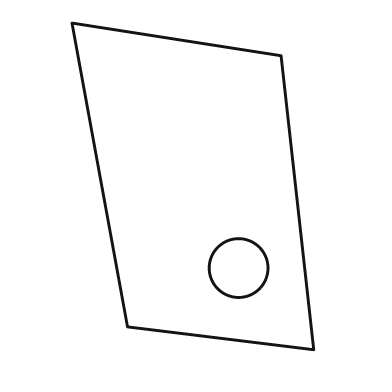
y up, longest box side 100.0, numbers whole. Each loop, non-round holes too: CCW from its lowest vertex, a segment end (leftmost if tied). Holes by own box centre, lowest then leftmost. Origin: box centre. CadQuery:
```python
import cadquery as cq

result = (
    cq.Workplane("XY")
    .moveTo(37.0, -50.0)
    .lineTo(27.0, 40.0)
    .lineTo(-37.0, 50.0)
    .lineTo(-20.0, -43.0)
    .close()
    .moveTo(14.0, -25.0)
    .circle(9.0)
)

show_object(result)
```